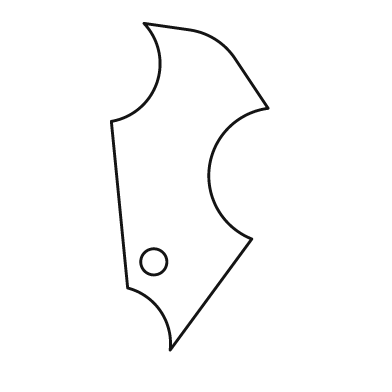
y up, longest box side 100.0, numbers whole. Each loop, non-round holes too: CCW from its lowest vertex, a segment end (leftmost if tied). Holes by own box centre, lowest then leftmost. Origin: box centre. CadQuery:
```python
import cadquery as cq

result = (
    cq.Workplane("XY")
    .moveTo(-6.0, -50.0)
    .lineTo(19.0, -16.0)
    .threePointArc((6.0, 6.0), (24.0, 24.0))
    .lineTo(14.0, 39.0)
    .threePointArc((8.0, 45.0), (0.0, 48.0))
    .lineTo(-14.0, 50.0)
    .threePointArc((-10.0, 32.0), (-24.0, 20.0))
    .lineTo(-19.0, -31.0)
    .threePointArc((-9.0, -38.0), (-6.0, -50.0))
    .close()
    .moveTo(-11.0, -23.0)
    .circle(4.0)
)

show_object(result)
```